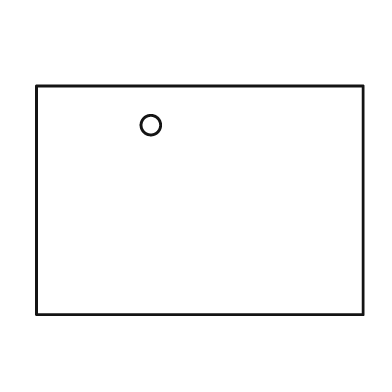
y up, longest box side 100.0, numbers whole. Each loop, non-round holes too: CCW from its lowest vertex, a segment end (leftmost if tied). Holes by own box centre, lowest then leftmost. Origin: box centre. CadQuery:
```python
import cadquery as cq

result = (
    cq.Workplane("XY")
    .moveTo(-50.0, -35.0)
    .lineTo(50.0, -35.0)
    .lineTo(50.0, 35.0)
    .lineTo(-50.0, 35.0)
    .close()
    .moveTo(-15.0, 23.0)
    .circle(3.0)
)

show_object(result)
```